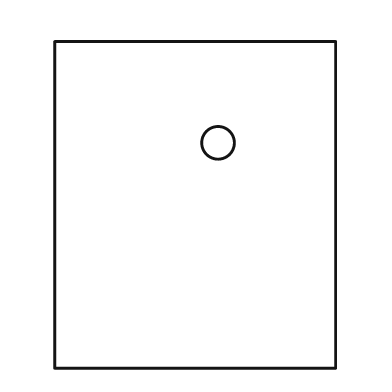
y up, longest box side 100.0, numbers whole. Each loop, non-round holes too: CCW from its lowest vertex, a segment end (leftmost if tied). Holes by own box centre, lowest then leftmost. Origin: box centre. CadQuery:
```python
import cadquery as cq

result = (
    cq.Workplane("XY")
    .moveTo(-43.0, -50.0)
    .lineTo(43.0, -50.0)
    .lineTo(43.0, 50.0)
    .lineTo(-43.0, 50.0)
    .close()
    .moveTo(7.0, 19.0)
    .circle(5.0)
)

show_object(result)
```